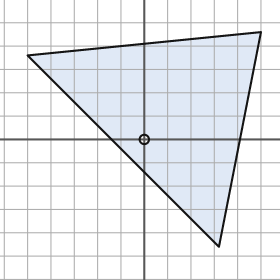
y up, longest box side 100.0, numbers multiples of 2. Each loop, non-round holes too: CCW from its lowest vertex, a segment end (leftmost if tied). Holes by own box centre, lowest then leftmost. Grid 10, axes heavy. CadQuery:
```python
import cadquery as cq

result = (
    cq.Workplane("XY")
    .moveTo(32.0, -46.0)
    .lineTo(50.0, 46.0)
    .lineTo(-50.0, 36.0)
    .close()
    .moveTo(0.0, 0.0)
    .circle(2.0)
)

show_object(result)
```